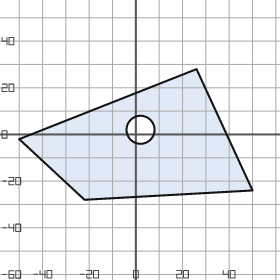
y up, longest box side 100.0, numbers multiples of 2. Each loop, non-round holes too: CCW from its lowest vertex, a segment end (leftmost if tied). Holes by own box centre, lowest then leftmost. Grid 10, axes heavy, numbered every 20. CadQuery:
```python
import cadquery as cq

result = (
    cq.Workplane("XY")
    .moveTo(-22.0, -28.0)
    .lineTo(50.0, -24.0)
    .lineTo(26.0, 28.0)
    .lineTo(-50.0, -2.0)
    .close()
    .moveTo(2.0, 2.0)
    .circle(6.0)
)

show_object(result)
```